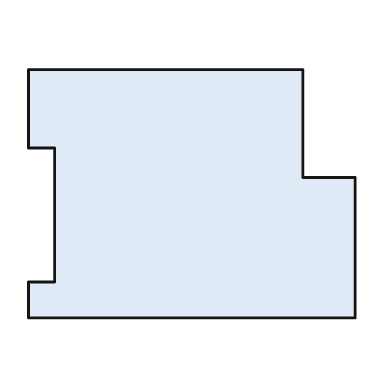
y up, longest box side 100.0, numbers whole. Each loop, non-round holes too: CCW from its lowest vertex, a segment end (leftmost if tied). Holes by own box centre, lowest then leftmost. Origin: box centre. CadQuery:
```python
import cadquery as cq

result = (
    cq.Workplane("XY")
    .moveTo(-50.0, -38.0)
    .lineTo(50.0, -38.0)
    .lineTo(50.0, 5.0)
    .lineTo(34.0, 5.0)
    .lineTo(34.0, 38.0)
    .lineTo(-50.0, 38.0)
    .lineTo(-50.0, 14.0)
    .lineTo(-42.0, 14.0)
    .lineTo(-42.0, -27.0)
    .lineTo(-50.0, -27.0)
    .close()
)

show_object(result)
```